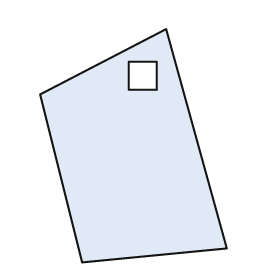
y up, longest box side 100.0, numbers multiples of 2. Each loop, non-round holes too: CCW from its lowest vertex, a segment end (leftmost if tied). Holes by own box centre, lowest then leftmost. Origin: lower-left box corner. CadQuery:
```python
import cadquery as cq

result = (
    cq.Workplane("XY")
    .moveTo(18.0, 0.0)
    .lineTo(80.0, 6.0)
    .lineTo(54.0, 100.0)
    .lineTo(0.0, 72.0)
    .close()
    .moveTo(38.0, 74.0)
    .lineTo(50.0, 74.0)
    .lineTo(50.0, 86.0)
    .lineTo(38.0, 86.0)
    .close()
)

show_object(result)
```